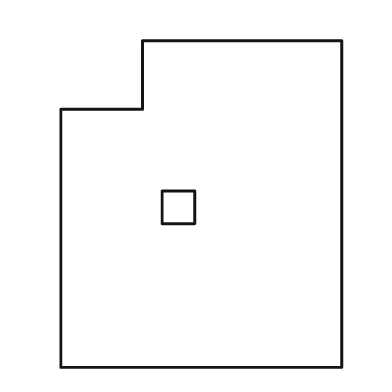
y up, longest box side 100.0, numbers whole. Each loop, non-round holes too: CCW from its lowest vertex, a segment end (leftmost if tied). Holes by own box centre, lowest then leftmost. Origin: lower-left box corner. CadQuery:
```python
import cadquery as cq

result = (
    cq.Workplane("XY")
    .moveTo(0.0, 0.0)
    .lineTo(86.0, 0.0)
    .lineTo(86.0, 100.0)
    .lineTo(25.0, 100.0)
    .lineTo(25.0, 79.0)
    .lineTo(0.0, 79.0)
    .close()
    .moveTo(31.0, 44.0)
    .lineTo(41.0, 44.0)
    .lineTo(41.0, 54.0)
    .lineTo(31.0, 54.0)
    .close()
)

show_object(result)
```